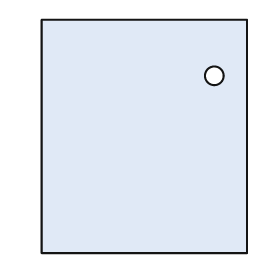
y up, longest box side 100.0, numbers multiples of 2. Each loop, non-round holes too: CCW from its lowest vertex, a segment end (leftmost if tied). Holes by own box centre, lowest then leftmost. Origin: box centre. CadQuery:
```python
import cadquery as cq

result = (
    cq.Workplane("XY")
    .moveTo(-44.0, -50.0)
    .lineTo(44.0, -50.0)
    .lineTo(44.0, 50.0)
    .lineTo(-44.0, 50.0)
    .close()
    .moveTo(30.0, 26.0)
    .circle(4.0)
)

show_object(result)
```